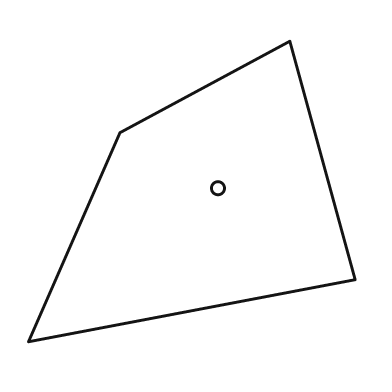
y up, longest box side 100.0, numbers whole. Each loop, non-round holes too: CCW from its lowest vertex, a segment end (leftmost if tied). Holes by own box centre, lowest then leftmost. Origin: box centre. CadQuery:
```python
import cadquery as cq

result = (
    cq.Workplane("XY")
    .moveTo(-50.0, -46.0)
    .lineTo(50.0, -27.0)
    .lineTo(30.0, 46.0)
    .lineTo(-22.0, 18.0)
    .close()
    .moveTo(8.0, 1.0)
    .circle(2.0)
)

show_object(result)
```